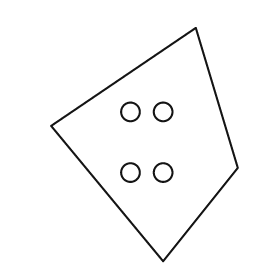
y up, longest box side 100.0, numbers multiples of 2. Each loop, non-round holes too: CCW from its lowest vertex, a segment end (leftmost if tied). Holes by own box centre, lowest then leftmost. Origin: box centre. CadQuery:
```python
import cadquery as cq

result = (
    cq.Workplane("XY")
    .moveTo(8.0, -50.0)
    .lineTo(40.0, -10.0)
    .lineTo(22.0, 50.0)
    .lineTo(-40.0, 8.0)
    .close()
    .moveTo(-6.0, -12.0)
    .circle(4.0)
    .moveTo(8.0, -12.0)
    .circle(4.0)
    .moveTo(-6.0, 14.0)
    .circle(4.0)
    .moveTo(8.0, 14.0)
    .circle(4.0)
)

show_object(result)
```